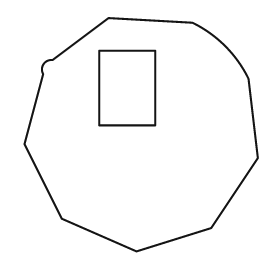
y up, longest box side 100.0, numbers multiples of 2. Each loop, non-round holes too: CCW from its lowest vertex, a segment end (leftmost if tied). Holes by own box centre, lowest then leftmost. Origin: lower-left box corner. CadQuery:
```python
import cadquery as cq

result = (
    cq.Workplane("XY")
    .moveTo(48.0, 0.0)
    .lineTo(80.0, 10.0)
    .lineTo(100.0, 40.0)
    .lineTo(96.0, 74.0)
    .threePointArc((86.0, 88.0), (72.0, 98.0))
    .lineTo(36.0, 100.0)
    .lineTo(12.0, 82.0)
    .threePointArc((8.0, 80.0), (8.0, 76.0))
    .lineTo(0.0, 46.0)
    .lineTo(16.0, 14.0)
    .close()
    .moveTo(32.0, 54.0)
    .lineTo(56.0, 54.0)
    .lineTo(56.0, 86.0)
    .lineTo(32.0, 86.0)
    .close()
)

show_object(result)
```